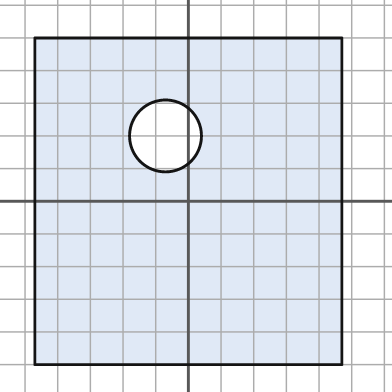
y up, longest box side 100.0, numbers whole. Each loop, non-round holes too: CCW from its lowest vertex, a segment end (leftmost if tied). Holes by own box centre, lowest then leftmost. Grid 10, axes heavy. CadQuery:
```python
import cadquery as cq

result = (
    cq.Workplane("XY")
    .moveTo(-47.0, -50.0)
    .lineTo(47.0, -50.0)
    .lineTo(47.0, 50.0)
    .lineTo(-47.0, 50.0)
    .close()
    .moveTo(-7.0, 20.0)
    .circle(11.0)
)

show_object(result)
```